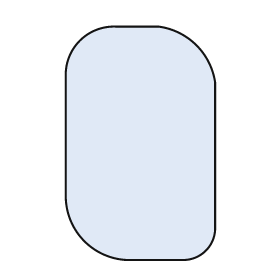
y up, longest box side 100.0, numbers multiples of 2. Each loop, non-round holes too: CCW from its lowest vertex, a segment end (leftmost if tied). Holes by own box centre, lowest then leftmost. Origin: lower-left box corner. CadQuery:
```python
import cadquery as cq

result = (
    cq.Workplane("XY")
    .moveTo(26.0, 0.0)
    .lineTo(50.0, 0.0)
    .threePointArc((60.0, 4.0), (64.0, 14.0))
    .lineTo(64.0, 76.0)
    .threePointArc((56.0, 92.0), (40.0, 100.0))
    .lineTo(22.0, 100.0)
    .threePointArc((6.0, 94.0), (0.0, 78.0))
    .lineTo(0.0, 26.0)
    .threePointArc((8.0, 8.0), (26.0, 0.0))
    .close()
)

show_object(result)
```